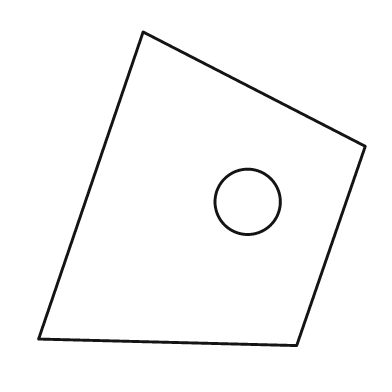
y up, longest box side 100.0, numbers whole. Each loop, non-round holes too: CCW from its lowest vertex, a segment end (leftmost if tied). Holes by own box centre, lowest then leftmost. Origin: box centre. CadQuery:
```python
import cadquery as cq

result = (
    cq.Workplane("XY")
    .moveTo(29.0, -48.0)
    .lineTo(50.0, 13.0)
    .lineTo(-18.0, 48.0)
    .lineTo(-50.0, -46.0)
    .close()
    .moveTo(14.0, -4.0)
    .circle(10.0)
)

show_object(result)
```